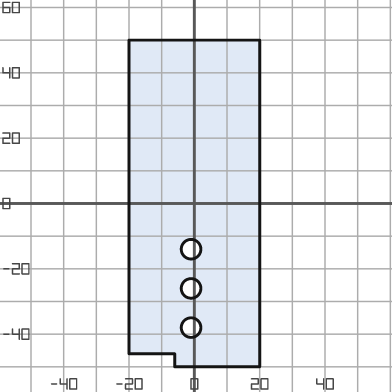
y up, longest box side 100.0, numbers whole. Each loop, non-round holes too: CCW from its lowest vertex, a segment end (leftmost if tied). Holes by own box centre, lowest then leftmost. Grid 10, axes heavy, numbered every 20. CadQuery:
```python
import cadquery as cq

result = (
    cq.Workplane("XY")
    .moveTo(-6.0, -50.0)
    .lineTo(20.0, -50.0)
    .lineTo(20.0, 50.0)
    .lineTo(-20.0, 50.0)
    .lineTo(-20.0, -46.0)
    .lineTo(-6.0, -46.0)
    .close()
    .moveTo(-1.0, -38.0)
    .circle(3.0)
    .moveTo(-1.0, -26.0)
    .circle(3.0)
    .moveTo(-1.0, -14.0)
    .circle(3.0)
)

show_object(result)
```